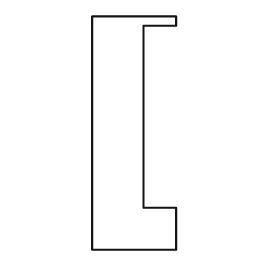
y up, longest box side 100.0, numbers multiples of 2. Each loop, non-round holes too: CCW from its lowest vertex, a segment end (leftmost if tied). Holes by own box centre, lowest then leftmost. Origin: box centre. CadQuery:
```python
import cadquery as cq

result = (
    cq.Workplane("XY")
    .moveTo(-18.0, -50.0)
    .lineTo(18.0, -50.0)
    .lineTo(18.0, -32.0)
    .lineTo(4.0, -32.0)
    .lineTo(4.0, 46.0)
    .lineTo(18.0, 46.0)
    .lineTo(18.0, 50.0)
    .lineTo(-18.0, 50.0)
    .close()
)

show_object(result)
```